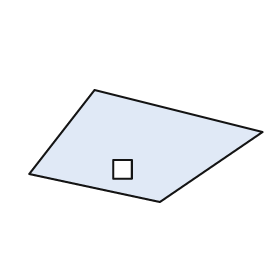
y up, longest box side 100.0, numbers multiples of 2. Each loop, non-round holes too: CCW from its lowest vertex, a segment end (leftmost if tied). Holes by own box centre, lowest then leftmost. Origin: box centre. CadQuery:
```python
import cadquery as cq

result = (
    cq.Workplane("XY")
    .moveTo(6.0, -24.0)
    .lineTo(50.0, 6.0)
    .lineTo(-22.0, 24.0)
    .lineTo(-50.0, -12.0)
    .close()
    .moveTo(-14.0, -14.0)
    .lineTo(-6.0, -14.0)
    .lineTo(-6.0, -6.0)
    .lineTo(-14.0, -6.0)
    .close()
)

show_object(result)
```